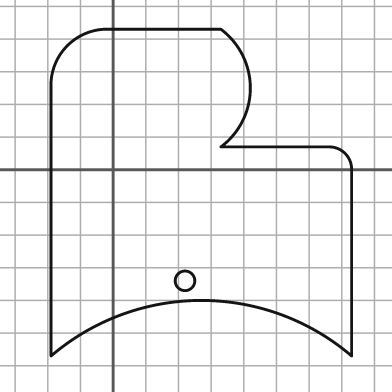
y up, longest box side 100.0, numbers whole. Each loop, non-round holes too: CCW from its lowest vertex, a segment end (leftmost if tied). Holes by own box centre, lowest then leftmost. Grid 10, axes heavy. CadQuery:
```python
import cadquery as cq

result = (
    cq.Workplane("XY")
    .moveTo(-19.0, -57.0)
    .threePointArc((27.0, -40.0), (73.0, -57.0))
    .lineTo(73.0, 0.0)
    .threePointArc((71.0, 5.0), (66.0, 7.0))
    .lineTo(33.0, 7.0)
    .threePointArc((42.0, 25.0), (33.0, 43.0))
    .lineTo(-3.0, 43.0)
    .threePointArc((-14.0, 38.0), (-19.0, 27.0))
    .close()
    .moveTo(22.0, -34.0)
    .circle(3.0)
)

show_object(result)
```